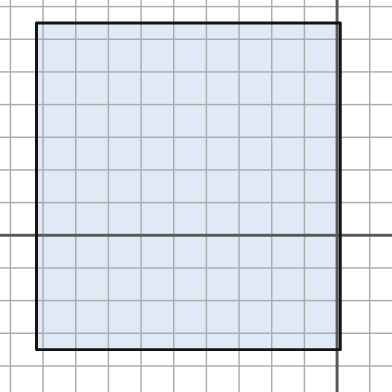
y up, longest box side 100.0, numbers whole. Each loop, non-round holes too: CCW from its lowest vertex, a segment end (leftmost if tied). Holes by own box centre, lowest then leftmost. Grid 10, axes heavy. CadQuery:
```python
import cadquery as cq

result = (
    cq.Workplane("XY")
    .moveTo(-92.0, -35.0)
    .lineTo(1.0, -35.0)
    .lineTo(1.0, 65.0)
    .lineTo(-92.0, 65.0)
    .close()
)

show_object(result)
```